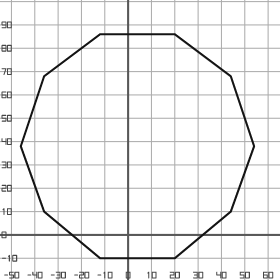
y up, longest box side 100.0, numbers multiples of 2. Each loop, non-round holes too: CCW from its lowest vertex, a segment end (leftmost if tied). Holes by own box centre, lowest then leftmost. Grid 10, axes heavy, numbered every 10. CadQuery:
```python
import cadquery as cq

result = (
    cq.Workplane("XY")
    .moveTo(-12.0, -10.0)
    .lineTo(20.0, -10.0)
    .lineTo(44.0, 10.0)
    .lineTo(54.0, 38.0)
    .lineTo(44.0, 68.0)
    .lineTo(20.0, 86.0)
    .lineTo(-12.0, 86.0)
    .lineTo(-36.0, 68.0)
    .lineTo(-46.0, 38.0)
    .lineTo(-36.0, 10.0)
    .close()
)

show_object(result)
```